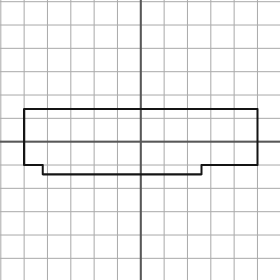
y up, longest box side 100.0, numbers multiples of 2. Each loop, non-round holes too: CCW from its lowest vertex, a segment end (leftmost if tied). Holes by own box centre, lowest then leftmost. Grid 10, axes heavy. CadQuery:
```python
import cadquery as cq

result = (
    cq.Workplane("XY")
    .moveTo(-42.0, -14.0)
    .lineTo(26.0, -14.0)
    .lineTo(26.0, -10.0)
    .lineTo(50.0, -10.0)
    .lineTo(50.0, 14.0)
    .lineTo(-50.0, 14.0)
    .lineTo(-50.0, -10.0)
    .lineTo(-42.0, -10.0)
    .close()
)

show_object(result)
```